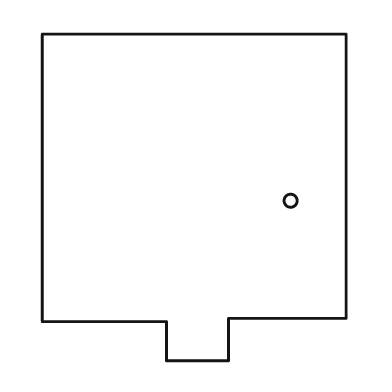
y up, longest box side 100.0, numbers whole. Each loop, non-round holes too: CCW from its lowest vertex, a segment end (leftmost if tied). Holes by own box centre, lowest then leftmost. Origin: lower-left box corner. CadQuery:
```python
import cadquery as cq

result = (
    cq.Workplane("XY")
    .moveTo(38.0, 0.0)
    .lineTo(57.0, 0.0)
    .lineTo(57.0, 13.0)
    .lineTo(93.0, 13.0)
    .lineTo(93.0, 100.0)
    .lineTo(0.0, 100.0)
    .lineTo(0.0, 12.0)
    .lineTo(38.0, 12.0)
    .close()
    .moveTo(76.0, 49.0)
    .circle(2.0)
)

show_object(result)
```